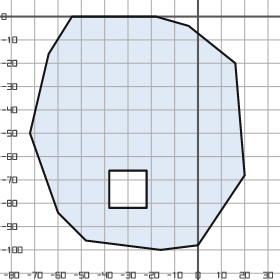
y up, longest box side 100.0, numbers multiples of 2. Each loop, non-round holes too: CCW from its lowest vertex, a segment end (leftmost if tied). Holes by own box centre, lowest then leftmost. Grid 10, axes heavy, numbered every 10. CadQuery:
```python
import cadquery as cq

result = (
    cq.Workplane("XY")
    .moveTo(-16.0, -100.0)
    .lineTo(0.0, -98.0)
    .lineTo(20.0, -68.0)
    .lineTo(16.0, -20.0)
    .lineTo(-4.0, -4.0)
    .lineTo(-18.0, 0.0)
    .lineTo(-54.0, 0.0)
    .lineTo(-64.0, -16.0)
    .lineTo(-72.0, -50.0)
    .lineTo(-60.0, -84.0)
    .lineTo(-48.0, -96.0)
    .close()
    .moveTo(-38.0, -82.0)
    .lineTo(-22.0, -82.0)
    .lineTo(-22.0, -66.0)
    .lineTo(-38.0, -66.0)
    .close()
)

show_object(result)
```